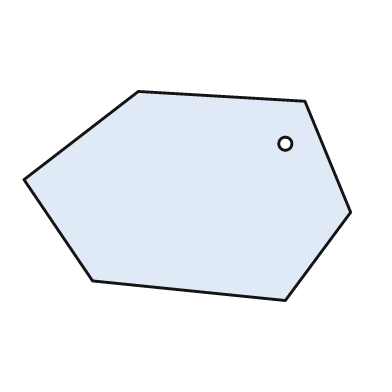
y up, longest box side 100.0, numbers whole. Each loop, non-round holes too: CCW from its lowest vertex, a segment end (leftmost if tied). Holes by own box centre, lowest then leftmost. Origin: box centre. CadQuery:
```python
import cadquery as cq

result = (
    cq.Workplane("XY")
    .moveTo(30.0, -32.0)
    .lineTo(50.0, -5.0)
    .lineTo(36.0, 29.0)
    .lineTo(-15.0, 32.0)
    .lineTo(-50.0, 5.0)
    .lineTo(-29.0, -26.0)
    .close()
    .moveTo(30.0, 16.0)
    .circle(2.0)
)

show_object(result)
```